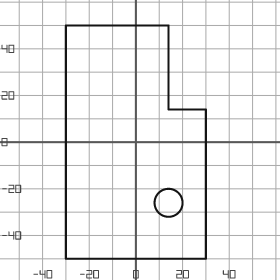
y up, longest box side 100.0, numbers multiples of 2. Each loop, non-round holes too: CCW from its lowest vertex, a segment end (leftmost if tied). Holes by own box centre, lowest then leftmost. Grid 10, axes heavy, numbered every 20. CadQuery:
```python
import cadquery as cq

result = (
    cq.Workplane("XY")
    .moveTo(-30.0, -50.0)
    .lineTo(30.0, -50.0)
    .lineTo(30.0, 14.0)
    .lineTo(14.0, 14.0)
    .lineTo(14.0, 50.0)
    .lineTo(-30.0, 50.0)
    .close()
    .moveTo(14.0, -26.0)
    .circle(6.0)
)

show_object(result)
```